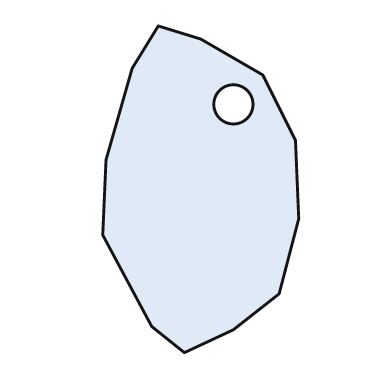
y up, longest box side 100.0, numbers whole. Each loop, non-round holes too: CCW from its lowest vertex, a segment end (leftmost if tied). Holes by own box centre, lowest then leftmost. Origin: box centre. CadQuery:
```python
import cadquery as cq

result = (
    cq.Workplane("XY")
    .moveTo(-5.0, -50.0)
    .lineTo(10.0, -43.0)
    .lineTo(24.0, -32.0)
    .lineTo(30.0, -9.0)
    .lineTo(29.0, 15.0)
    .lineTo(19.0, 35.0)
    .lineTo(0.0, 46.0)
    .lineTo(-13.0, 50.0)
    .lineTo(-21.0, 37.0)
    .lineTo(-29.0, 9.0)
    .lineTo(-30.0, -14.0)
    .lineTo(-15.0, -42.0)
    .close()
    .moveTo(10.0, 26.0)
    .circle(6.0)
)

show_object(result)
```